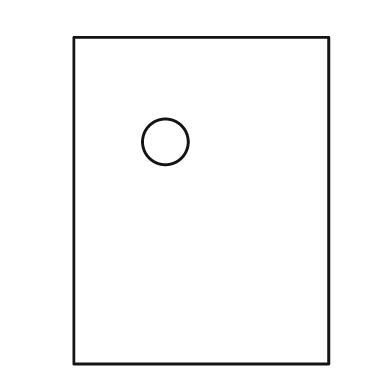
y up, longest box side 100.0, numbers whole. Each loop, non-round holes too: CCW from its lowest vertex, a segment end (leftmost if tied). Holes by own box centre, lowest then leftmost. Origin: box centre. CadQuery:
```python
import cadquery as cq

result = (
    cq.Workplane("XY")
    .moveTo(-39.0, -50.0)
    .lineTo(39.0, -50.0)
    .lineTo(39.0, 50.0)
    .lineTo(-39.0, 50.0)
    .close()
    .moveTo(-11.0, 18.0)
    .circle(7.0)
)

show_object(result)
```